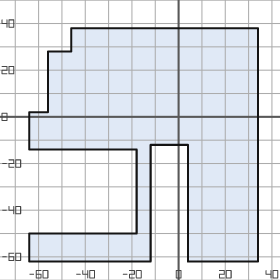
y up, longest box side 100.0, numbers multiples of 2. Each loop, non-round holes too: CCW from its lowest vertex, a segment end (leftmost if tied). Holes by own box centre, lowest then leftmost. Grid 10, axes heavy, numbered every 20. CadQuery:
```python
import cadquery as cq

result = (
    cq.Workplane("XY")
    .moveTo(-64.0, -62.0)
    .lineTo(-12.0, -62.0)
    .lineTo(-12.0, -12.0)
    .lineTo(4.0, -12.0)
    .lineTo(4.0, -62.0)
    .lineTo(34.0, -62.0)
    .lineTo(34.0, 38.0)
    .lineTo(-46.0, 38.0)
    .lineTo(-46.0, 28.0)
    .lineTo(-56.0, 28.0)
    .lineTo(-56.0, 2.0)
    .lineTo(-64.0, 2.0)
    .lineTo(-64.0, -14.0)
    .lineTo(-18.0, -14.0)
    .lineTo(-18.0, -50.0)
    .lineTo(-64.0, -50.0)
    .close()
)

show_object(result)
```